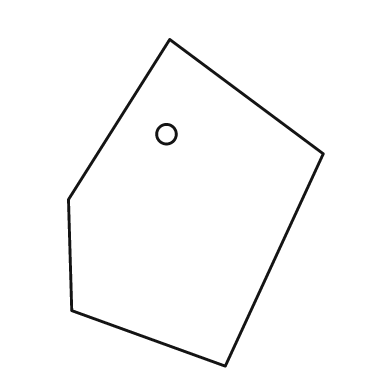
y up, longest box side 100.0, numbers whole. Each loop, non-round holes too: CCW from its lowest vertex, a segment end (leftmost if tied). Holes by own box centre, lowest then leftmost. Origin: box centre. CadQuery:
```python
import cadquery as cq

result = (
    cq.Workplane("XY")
    .moveTo(9.0, -50.0)
    .lineTo(39.0, 15.0)
    .lineTo(-8.0, 50.0)
    .lineTo(-39.0, 1.0)
    .lineTo(-38.0, -33.0)
    .close()
    .moveTo(-9.0, 21.0)
    .circle(3.0)
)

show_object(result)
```